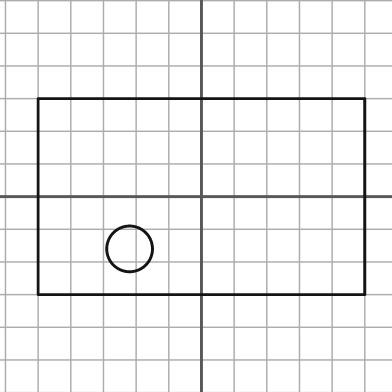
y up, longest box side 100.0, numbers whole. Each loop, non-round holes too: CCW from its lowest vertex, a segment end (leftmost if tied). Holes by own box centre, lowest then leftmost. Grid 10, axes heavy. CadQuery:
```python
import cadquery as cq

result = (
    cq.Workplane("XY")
    .moveTo(-50.0, -30.0)
    .lineTo(50.0, -30.0)
    .lineTo(50.0, 30.0)
    .lineTo(-50.0, 30.0)
    .close()
    .moveTo(-22.0, -16.0)
    .circle(7.0)
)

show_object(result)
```